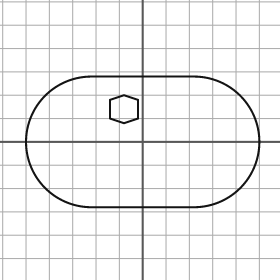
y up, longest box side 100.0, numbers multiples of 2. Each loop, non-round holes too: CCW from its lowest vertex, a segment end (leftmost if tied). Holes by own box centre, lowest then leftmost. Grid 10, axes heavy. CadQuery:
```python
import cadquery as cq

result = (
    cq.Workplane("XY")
    .moveTo(-22.0, -28.0)
    .lineTo(22.0, -28.0)
    .threePointArc((50.0, 0.0), (22.0, 28.0))
    .lineTo(-22.0, 28.0)
    .threePointArc((-50.0, 0.0), (-22.0, -28.0))
    .close()
    .moveTo(-8.0, 8.0)
    .lineTo(-2.0, 10.0)
    .lineTo(-2.0, 18.0)
    .lineTo(-8.0, 20.0)
    .lineTo(-14.0, 18.0)
    .lineTo(-14.0, 10.0)
    .close()
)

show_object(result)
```